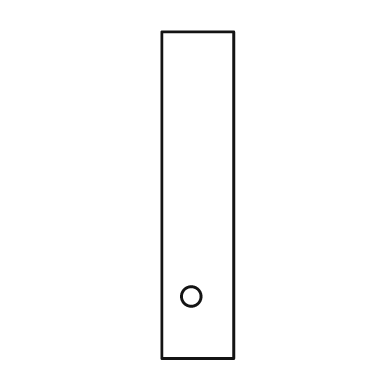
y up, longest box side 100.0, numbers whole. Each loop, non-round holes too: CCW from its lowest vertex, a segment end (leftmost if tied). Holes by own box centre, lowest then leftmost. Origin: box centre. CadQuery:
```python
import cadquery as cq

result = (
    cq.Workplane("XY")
    .moveTo(-11.0, -50.0)
    .lineTo(11.0, -50.0)
    .lineTo(11.0, 50.0)
    .lineTo(-11.0, 50.0)
    .close()
    .moveTo(-2.0, -31.0)
    .circle(3.0)
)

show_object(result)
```